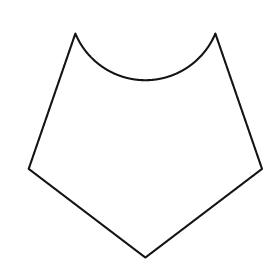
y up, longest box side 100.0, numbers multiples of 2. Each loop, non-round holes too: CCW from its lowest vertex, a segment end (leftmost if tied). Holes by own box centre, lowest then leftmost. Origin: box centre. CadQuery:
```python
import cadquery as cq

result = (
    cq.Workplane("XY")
    .moveTo(0.0, -48.0)
    .lineTo(50.0, -10.0)
    .lineTo(30.0, 48.0)
    .threePointArc((0.0, 28.0), (-30.0, 48.0))
    .lineTo(-50.0, -10.0)
    .close()
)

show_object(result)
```